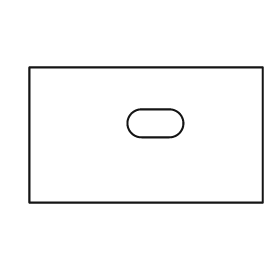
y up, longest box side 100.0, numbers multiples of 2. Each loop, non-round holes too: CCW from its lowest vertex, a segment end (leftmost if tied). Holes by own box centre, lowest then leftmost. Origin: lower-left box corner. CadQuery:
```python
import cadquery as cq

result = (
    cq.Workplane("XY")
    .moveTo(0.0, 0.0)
    .lineTo(100.0, 0.0)
    .lineTo(100.0, 58.0)
    .lineTo(0.0, 58.0)
    .close()
    .moveTo(48.0, 28.0)
    .lineTo(60.0, 28.0)
    .threePointArc((66.0, 34.0), (60.0, 40.0))
    .lineTo(48.0, 40.0)
    .threePointArc((42.0, 34.0), (48.0, 28.0))
    .close()
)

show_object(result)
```